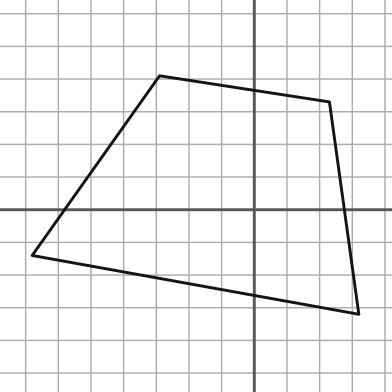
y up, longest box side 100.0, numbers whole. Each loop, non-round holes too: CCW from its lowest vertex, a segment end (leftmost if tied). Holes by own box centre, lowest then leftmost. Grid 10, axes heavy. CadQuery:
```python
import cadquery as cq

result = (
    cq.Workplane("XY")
    .moveTo(32.0, -32.0)
    .lineTo(23.0, 33.0)
    .lineTo(-29.0, 41.0)
    .lineTo(-68.0, -14.0)
    .close()
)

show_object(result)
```